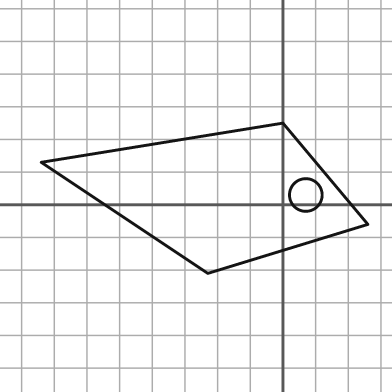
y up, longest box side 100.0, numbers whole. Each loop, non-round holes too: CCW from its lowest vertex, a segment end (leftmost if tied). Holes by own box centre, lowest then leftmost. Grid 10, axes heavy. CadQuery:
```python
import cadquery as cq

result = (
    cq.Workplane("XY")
    .moveTo(-23.0, -21.0)
    .lineTo(26.0, -6.0)
    .lineTo(0.0, 25.0)
    .lineTo(-74.0, 13.0)
    .close()
    .moveTo(7.0, 3.0)
    .circle(5.0)
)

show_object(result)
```